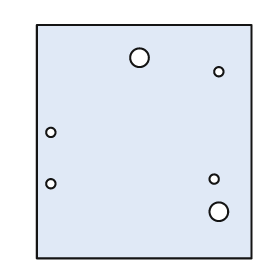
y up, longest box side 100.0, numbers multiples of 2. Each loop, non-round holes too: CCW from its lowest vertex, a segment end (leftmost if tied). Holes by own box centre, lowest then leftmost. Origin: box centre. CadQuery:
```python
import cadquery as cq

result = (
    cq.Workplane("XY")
    .moveTo(-46.0, -50.0)
    .lineTo(46.0, -50.0)
    .lineTo(46.0, 50.0)
    .lineTo(-46.0, 50.0)
    .close()
    .moveTo(32.0, -30.0)
    .circle(4.0)
    .moveTo(-40.0, -18.0)
    .circle(2.0)
    .moveTo(30.0, -16.0)
    .circle(2.0)
    .moveTo(-40.0, 4.0)
    .circle(2.0)
    .moveTo(32.0, 30.0)
    .circle(2.0)
    .moveTo(-2.0, 36.0)
    .circle(4.0)
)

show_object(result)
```